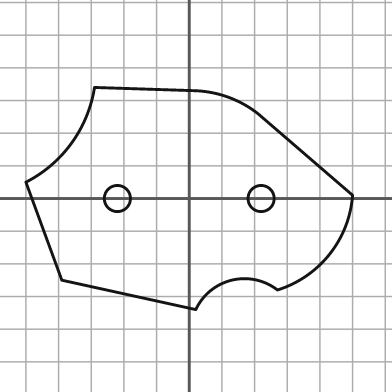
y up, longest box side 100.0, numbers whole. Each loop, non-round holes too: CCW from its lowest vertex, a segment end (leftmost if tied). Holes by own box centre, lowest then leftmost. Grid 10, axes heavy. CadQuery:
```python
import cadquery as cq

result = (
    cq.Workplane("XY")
    .moveTo(2.0, -34.0)
    .threePointArc((13.0, -25.0), (27.0, -28.0))
    .threePointArc((43.0, -17.0), (50.0, 1.0))
    .lineTo(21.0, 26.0)
    .threePointArc((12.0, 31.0), (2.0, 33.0))
    .lineTo(-29.0, 34.0)
    .threePointArc((-36.0, 17.0), (-50.0, 5.0))
    .lineTo(-39.0, -25.0)
    .close()
    .moveTo(-22.0, 0.0)
    .circle(4.0)
    .moveTo(22.0, 0.0)
    .circle(4.0)
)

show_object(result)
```